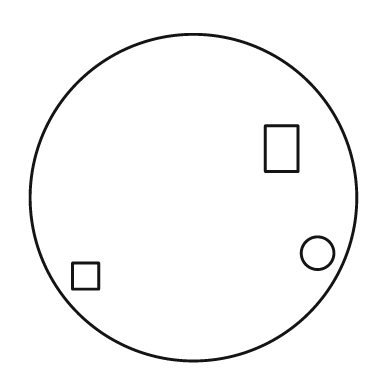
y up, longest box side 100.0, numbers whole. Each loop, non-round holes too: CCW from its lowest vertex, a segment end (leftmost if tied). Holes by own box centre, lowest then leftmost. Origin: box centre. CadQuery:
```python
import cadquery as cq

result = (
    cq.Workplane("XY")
    .moveTo(0.0, 0.0)
    .circle(50.0)
    .moveTo(-37.0, -28.0)
    .lineTo(-29.0, -28.0)
    .lineTo(-29.0, -20.0)
    .lineTo(-37.0, -20.0)
    .close()
    .moveTo(38.0, -17.0)
    .circle(5.0)
    .moveTo(22.0, 8.0)
    .lineTo(32.0, 8.0)
    .lineTo(32.0, 22.0)
    .lineTo(22.0, 22.0)
    .close()
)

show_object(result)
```